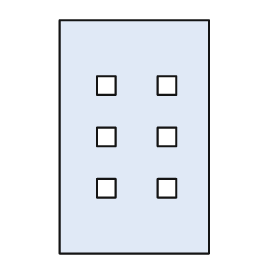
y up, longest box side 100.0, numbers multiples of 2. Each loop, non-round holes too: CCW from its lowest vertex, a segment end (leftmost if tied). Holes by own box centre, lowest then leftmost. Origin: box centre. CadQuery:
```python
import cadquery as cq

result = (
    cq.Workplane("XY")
    .moveTo(-32.0, -50.0)
    .lineTo(32.0, -50.0)
    .lineTo(32.0, 50.0)
    .lineTo(-32.0, 50.0)
    .close()
    .moveTo(-16.0, -26.0)
    .lineTo(-8.0, -26.0)
    .lineTo(-8.0, -18.0)
    .lineTo(-16.0, -18.0)
    .close()
    .moveTo(10.0, -26.0)
    .lineTo(18.0, -26.0)
    .lineTo(18.0, -18.0)
    .lineTo(10.0, -18.0)
    .close()
    .moveTo(-16.0, -4.0)
    .lineTo(-8.0, -4.0)
    .lineTo(-8.0, 4.0)
    .lineTo(-16.0, 4.0)
    .close()
    .moveTo(10.0, -4.0)
    .lineTo(18.0, -4.0)
    .lineTo(18.0, 4.0)
    .lineTo(10.0, 4.0)
    .close()
    .moveTo(-16.0, 18.0)
    .lineTo(-8.0, 18.0)
    .lineTo(-8.0, 26.0)
    .lineTo(-16.0, 26.0)
    .close()
    .moveTo(10.0, 18.0)
    .lineTo(18.0, 18.0)
    .lineTo(18.0, 26.0)
    .lineTo(10.0, 26.0)
    .close()
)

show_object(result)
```